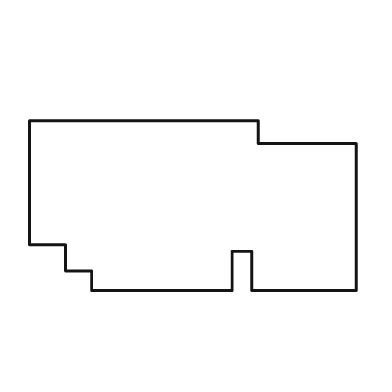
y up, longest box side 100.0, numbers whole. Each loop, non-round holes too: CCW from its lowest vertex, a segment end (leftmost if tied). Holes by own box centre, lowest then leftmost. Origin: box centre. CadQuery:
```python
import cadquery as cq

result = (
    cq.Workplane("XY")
    .moveTo(-31.0, -26.0)
    .lineTo(12.0, -26.0)
    .lineTo(12.0, -14.0)
    .lineTo(18.0, -14.0)
    .lineTo(18.0, -26.0)
    .lineTo(50.0, -26.0)
    .lineTo(50.0, 19.0)
    .lineTo(20.0, 19.0)
    .lineTo(20.0, 26.0)
    .lineTo(-50.0, 26.0)
    .lineTo(-50.0, -12.0)
    .lineTo(-39.0, -12.0)
    .lineTo(-39.0, -20.0)
    .lineTo(-31.0, -20.0)
    .close()
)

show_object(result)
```